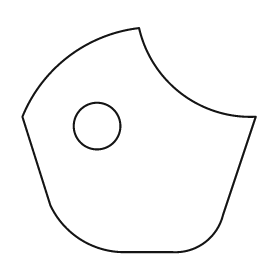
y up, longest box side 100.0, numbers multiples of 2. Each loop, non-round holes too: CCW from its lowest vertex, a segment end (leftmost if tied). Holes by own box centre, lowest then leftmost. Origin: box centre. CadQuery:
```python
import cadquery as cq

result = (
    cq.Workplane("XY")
    .moveTo(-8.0, -48.0)
    .lineTo(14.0, -48.0)
    .threePointArc((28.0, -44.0), (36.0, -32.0))
    .lineTo(50.0, 10.0)
    .threePointArc((18.0, 20.0), (0.0, 48.0))
    .threePointArc((-30.0, 36.0), (-50.0, 10.0))
    .lineTo(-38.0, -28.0)
    .threePointArc((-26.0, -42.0), (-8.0, -48.0))
    .close()
    .moveTo(-18.0, 6.0)
    .circle(10.0)
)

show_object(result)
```